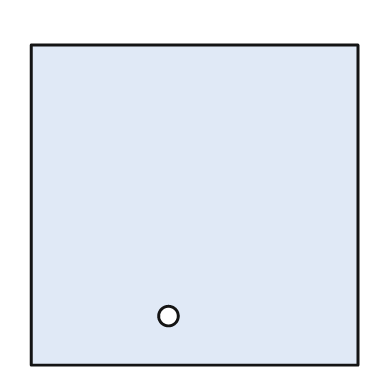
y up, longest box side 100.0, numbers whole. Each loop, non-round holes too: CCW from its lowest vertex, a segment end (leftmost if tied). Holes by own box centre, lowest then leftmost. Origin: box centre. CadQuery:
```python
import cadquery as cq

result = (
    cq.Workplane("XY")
    .moveTo(-50.0, -49.0)
    .lineTo(50.0, -49.0)
    .lineTo(50.0, 49.0)
    .lineTo(-50.0, 49.0)
    .close()
    .moveTo(-8.0, -34.0)
    .circle(3.0)
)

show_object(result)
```